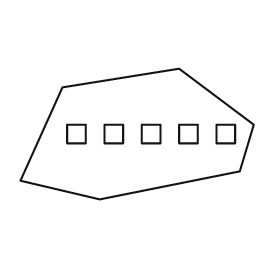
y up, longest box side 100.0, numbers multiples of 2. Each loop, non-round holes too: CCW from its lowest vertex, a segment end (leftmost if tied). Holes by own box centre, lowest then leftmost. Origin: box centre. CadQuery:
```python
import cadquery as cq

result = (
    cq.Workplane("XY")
    .moveTo(-16.0, -28.0)
    .lineTo(44.0, -16.0)
    .lineTo(50.0, 4.0)
    .lineTo(18.0, 28.0)
    .lineTo(-32.0, 20.0)
    .lineTo(-50.0, -20.0)
    .close()
    .moveTo(-30.0, -4.0)
    .lineTo(-22.0, -4.0)
    .lineTo(-22.0, 4.0)
    .lineTo(-30.0, 4.0)
    .close()
    .moveTo(-14.0, -4.0)
    .lineTo(-6.0, -4.0)
    .lineTo(-6.0, 4.0)
    .lineTo(-14.0, 4.0)
    .close()
    .moveTo(2.0, -4.0)
    .lineTo(10.0, -4.0)
    .lineTo(10.0, 4.0)
    .lineTo(2.0, 4.0)
    .close()
    .moveTo(18.0, -4.0)
    .lineTo(26.0, -4.0)
    .lineTo(26.0, 4.0)
    .lineTo(18.0, 4.0)
    .close()
    .moveTo(34.0, -4.0)
    .lineTo(42.0, -4.0)
    .lineTo(42.0, 4.0)
    .lineTo(34.0, 4.0)
    .close()
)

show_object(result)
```